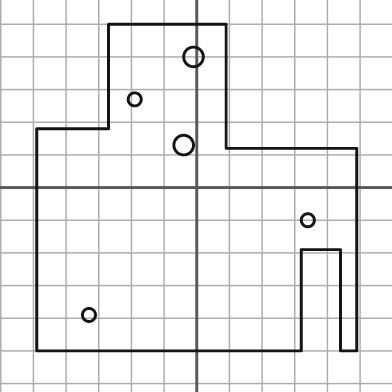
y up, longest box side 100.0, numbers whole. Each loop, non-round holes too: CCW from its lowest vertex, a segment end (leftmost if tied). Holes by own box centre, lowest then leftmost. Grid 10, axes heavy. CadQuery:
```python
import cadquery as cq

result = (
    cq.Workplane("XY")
    .moveTo(-49.0, -50.0)
    .lineTo(32.0, -50.0)
    .lineTo(32.0, -19.0)
    .lineTo(44.0, -19.0)
    .lineTo(44.0, -50.0)
    .lineTo(49.0, -50.0)
    .lineTo(49.0, 12.0)
    .lineTo(9.0, 12.0)
    .lineTo(9.0, 50.0)
    .lineTo(-27.0, 50.0)
    .lineTo(-27.0, 18.0)
    .lineTo(-49.0, 18.0)
    .close()
    .moveTo(-33.0, -39.0)
    .circle(2.0)
    .moveTo(34.0, -10.0)
    .circle(2.0)
    .moveTo(-4.0, 13.0)
    .circle(3.0)
    .moveTo(-19.0, 27.0)
    .circle(2.0)
    .moveTo(-1.0, 40.0)
    .circle(3.0)
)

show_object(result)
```